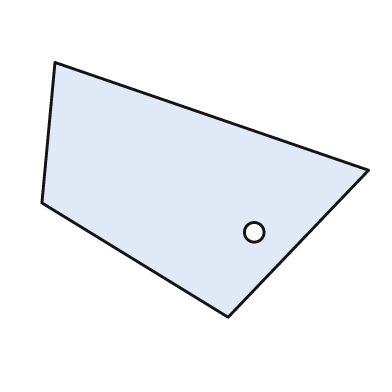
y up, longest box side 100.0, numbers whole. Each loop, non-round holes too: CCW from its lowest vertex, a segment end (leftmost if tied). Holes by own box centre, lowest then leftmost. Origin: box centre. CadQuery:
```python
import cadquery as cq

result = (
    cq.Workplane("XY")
    .moveTo(7.0, -39.0)
    .lineTo(50.0, 6.0)
    .lineTo(-46.0, 39.0)
    .lineTo(-50.0, -4.0)
    .close()
    .moveTo(15.0, -13.0)
    .circle(3.0)
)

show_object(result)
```